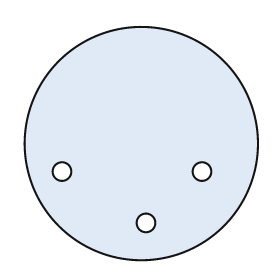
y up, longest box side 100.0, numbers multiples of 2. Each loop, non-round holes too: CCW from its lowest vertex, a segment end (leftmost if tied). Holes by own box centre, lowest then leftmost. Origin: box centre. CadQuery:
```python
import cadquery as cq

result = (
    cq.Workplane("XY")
    .moveTo(0.0, 0.0)
    .circle(50.0)
    .moveTo(2.0, -34.0)
    .circle(4.0)
    .moveTo(-34.0, -12.0)
    .circle(4.0)
    .moveTo(26.0, -12.0)
    .circle(4.0)
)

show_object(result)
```